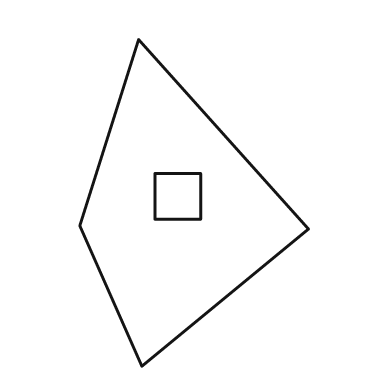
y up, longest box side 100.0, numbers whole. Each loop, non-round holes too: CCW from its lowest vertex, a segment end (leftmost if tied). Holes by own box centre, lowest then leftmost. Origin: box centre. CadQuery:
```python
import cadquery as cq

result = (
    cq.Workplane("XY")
    .moveTo(-16.0, -50.0)
    .lineTo(35.0, -8.0)
    .lineTo(-17.0, 50.0)
    .lineTo(-35.0, -7.0)
    .close()
    .moveTo(-12.0, -5.0)
    .lineTo(2.0, -5.0)
    .lineTo(2.0, 9.0)
    .lineTo(-12.0, 9.0)
    .close()
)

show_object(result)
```